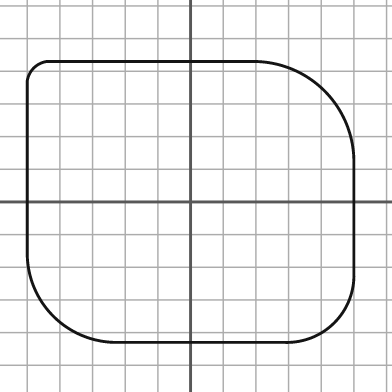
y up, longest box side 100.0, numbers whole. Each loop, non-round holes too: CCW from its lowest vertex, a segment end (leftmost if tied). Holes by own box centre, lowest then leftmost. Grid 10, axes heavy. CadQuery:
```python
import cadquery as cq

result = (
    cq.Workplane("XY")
    .moveTo(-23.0, -43.0)
    .lineTo(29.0, -43.0)
    .threePointArc((44.0, -37.0), (50.0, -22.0))
    .lineTo(50.0, 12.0)
    .threePointArc((41.0, 34.0), (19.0, 43.0))
    .lineTo(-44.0, 43.0)
    .threePointArc((-48.0, 41.0), (-50.0, 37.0))
    .lineTo(-50.0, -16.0)
    .threePointArc((-42.0, -35.0), (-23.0, -43.0))
    .close()
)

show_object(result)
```